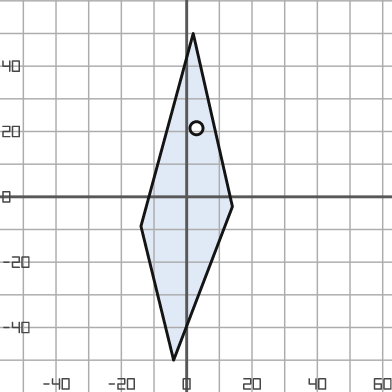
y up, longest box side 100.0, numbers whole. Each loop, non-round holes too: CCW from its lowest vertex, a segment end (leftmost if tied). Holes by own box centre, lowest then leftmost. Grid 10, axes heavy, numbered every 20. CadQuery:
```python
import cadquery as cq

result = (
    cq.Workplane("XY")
    .moveTo(-4.0, -50.0)
    .lineTo(14.0, -3.0)
    .lineTo(2.0, 50.0)
    .lineTo(-14.0, -9.0)
    .close()
    .moveTo(3.0, 21.0)
    .circle(2.0)
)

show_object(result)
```